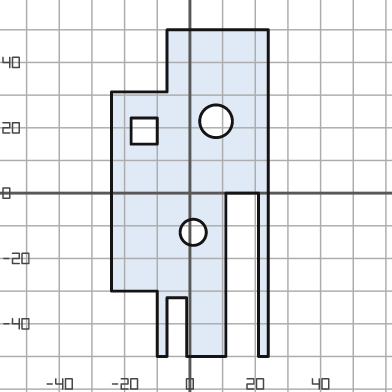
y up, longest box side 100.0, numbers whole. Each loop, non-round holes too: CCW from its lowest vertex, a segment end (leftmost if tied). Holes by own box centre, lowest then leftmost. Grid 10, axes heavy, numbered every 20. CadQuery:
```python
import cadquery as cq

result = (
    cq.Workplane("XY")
    .moveTo(-10.0, -50.0)
    .lineTo(-7.0, -50.0)
    .lineTo(-7.0, -32.0)
    .lineTo(-1.0, -32.0)
    .lineTo(-1.0, -50.0)
    .lineTo(11.0, -50.0)
    .lineTo(11.0, 0.0)
    .lineTo(21.0, 0.0)
    .lineTo(21.0, -50.0)
    .lineTo(24.0, -50.0)
    .lineTo(24.0, 50.0)
    .lineTo(-7.0, 50.0)
    .lineTo(-7.0, 31.0)
    .lineTo(-24.0, 31.0)
    .lineTo(-24.0, -30.0)
    .lineTo(-10.0, -30.0)
    .close()
    .moveTo(1.0, -12.0)
    .circle(4.0)
    .moveTo(-18.0, 15.0)
    .lineTo(-10.0, 15.0)
    .lineTo(-10.0, 23.0)
    .lineTo(-18.0, 23.0)
    .close()
    .moveTo(8.0, 22.0)
    .circle(5.0)
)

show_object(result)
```